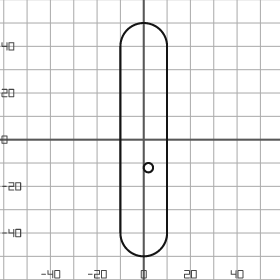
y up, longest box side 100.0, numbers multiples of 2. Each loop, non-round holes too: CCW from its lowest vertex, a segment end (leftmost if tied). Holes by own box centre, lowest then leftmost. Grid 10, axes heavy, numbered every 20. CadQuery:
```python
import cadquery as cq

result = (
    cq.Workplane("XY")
    .moveTo(-10.0, -40.0)
    .threePointArc((0.0, -50.0), (10.0, -40.0))
    .lineTo(10.0, 40.0)
    .threePointArc((0.0, 50.0), (-10.0, 40.0))
    .close()
    .moveTo(2.0, -12.0)
    .circle(2.0)
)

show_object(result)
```